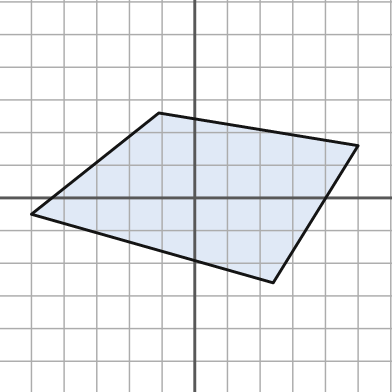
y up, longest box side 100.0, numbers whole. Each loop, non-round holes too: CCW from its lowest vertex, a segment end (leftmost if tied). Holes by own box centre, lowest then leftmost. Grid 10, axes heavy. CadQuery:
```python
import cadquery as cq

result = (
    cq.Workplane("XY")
    .moveTo(24.0, -26.0)
    .lineTo(50.0, 16.0)
    .lineTo(-11.0, 26.0)
    .lineTo(-50.0, -5.0)
    .close()
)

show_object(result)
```